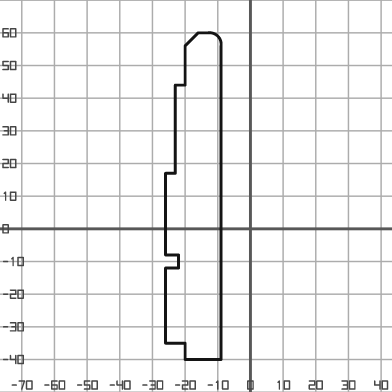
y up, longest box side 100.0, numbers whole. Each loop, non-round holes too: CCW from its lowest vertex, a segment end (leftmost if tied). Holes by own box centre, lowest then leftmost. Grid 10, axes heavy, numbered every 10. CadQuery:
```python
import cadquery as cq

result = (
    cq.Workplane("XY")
    .moveTo(-20.0, -40.0)
    .lineTo(-9.0, -40.0)
    .lineTo(-9.0, 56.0)
    .threePointArc((-10.0, 59.0), (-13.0, 60.0))
    .lineTo(-16.0, 60.0)
    .lineTo(-20.0, 56.0)
    .lineTo(-20.0, 44.0)
    .lineTo(-23.0, 44.0)
    .lineTo(-23.0, 17.0)
    .lineTo(-26.0, 17.0)
    .lineTo(-26.0, -8.0)
    .lineTo(-22.0, -8.0)
    .lineTo(-22.0, -12.0)
    .lineTo(-26.0, -12.0)
    .lineTo(-26.0, -35.0)
    .lineTo(-20.0, -35.0)
    .close()
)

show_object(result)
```